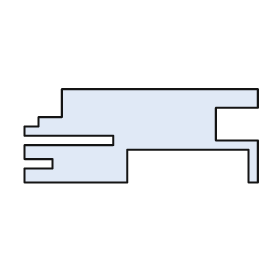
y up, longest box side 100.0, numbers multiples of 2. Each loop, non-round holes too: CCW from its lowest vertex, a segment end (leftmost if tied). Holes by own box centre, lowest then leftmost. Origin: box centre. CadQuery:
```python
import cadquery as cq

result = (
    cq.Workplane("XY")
    .moveTo(-50.0, -20.0)
    .lineTo(-6.0, -20.0)
    .lineTo(-6.0, -6.0)
    .lineTo(46.0, -6.0)
    .lineTo(46.0, -20.0)
    .lineTo(50.0, -20.0)
    .lineTo(50.0, -2.0)
    .lineTo(32.0, -2.0)
    .lineTo(32.0, 12.0)
    .lineTo(50.0, 12.0)
    .lineTo(50.0, 20.0)
    .lineTo(-34.0, 20.0)
    .lineTo(-34.0, 8.0)
    .lineTo(-44.0, 8.0)
    .lineTo(-44.0, 4.0)
    .lineTo(-50.0, 4.0)
    .lineTo(-50.0, 0.0)
    .lineTo(-12.0, 0.0)
    .lineTo(-12.0, -4.0)
    .lineTo(-50.0, -4.0)
    .lineTo(-50.0, -10.0)
    .lineTo(-38.0, -10.0)
    .lineTo(-38.0, -14.0)
    .lineTo(-50.0, -14.0)
    .close()
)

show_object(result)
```